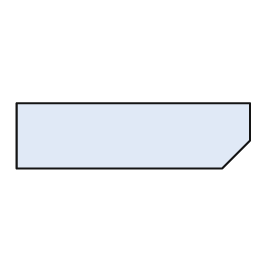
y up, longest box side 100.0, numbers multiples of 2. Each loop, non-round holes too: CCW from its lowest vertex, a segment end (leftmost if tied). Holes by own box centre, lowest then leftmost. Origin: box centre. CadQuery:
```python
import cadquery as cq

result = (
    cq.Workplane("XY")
    .moveTo(-50.0, -14.0)
    .lineTo(38.0, -14.0)
    .lineTo(50.0, -2.0)
    .lineTo(50.0, 14.0)
    .lineTo(-50.0, 14.0)
    .close()
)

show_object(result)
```